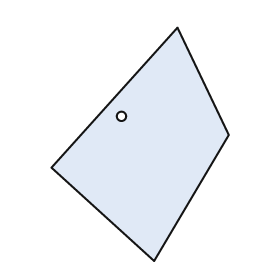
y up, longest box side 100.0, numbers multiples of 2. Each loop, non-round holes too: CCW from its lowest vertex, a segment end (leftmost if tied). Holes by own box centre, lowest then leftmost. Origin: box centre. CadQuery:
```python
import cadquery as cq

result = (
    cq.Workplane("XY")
    .moveTo(6.0, -50.0)
    .lineTo(38.0, 4.0)
    .lineTo(16.0, 50.0)
    .lineTo(-38.0, -10.0)
    .close()
    .moveTo(-8.0, 12.0)
    .circle(2.0)
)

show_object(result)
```